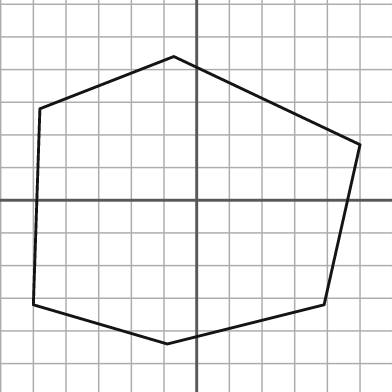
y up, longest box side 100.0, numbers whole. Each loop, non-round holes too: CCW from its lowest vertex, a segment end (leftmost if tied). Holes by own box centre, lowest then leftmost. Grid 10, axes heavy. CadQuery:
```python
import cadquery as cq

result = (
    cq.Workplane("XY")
    .moveTo(-9.0, -44.0)
    .lineTo(39.0, -32.0)
    .lineTo(50.0, 17.0)
    .lineTo(-7.0, 44.0)
    .lineTo(-48.0, 28.0)
    .lineTo(-50.0, -32.0)
    .close()
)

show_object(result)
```